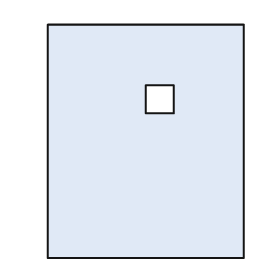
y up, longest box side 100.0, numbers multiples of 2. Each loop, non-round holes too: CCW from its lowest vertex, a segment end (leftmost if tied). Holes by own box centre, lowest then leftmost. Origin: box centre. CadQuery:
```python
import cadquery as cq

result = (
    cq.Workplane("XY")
    .moveTo(-42.0, -50.0)
    .lineTo(42.0, -50.0)
    .lineTo(42.0, 50.0)
    .lineTo(-42.0, 50.0)
    .close()
    .moveTo(0.0, 12.0)
    .lineTo(12.0, 12.0)
    .lineTo(12.0, 24.0)
    .lineTo(0.0, 24.0)
    .close()
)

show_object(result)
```